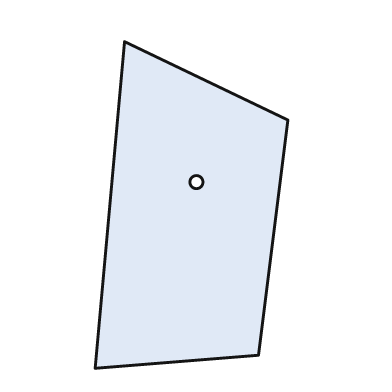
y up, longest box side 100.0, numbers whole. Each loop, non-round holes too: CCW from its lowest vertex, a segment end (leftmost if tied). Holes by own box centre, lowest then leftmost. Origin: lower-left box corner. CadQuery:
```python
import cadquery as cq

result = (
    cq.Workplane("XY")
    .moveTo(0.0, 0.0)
    .lineTo(50.0, 4.0)
    .lineTo(59.0, 76.0)
    .lineTo(9.0, 100.0)
    .close()
    .moveTo(31.0, 57.0)
    .circle(2.0)
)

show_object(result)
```